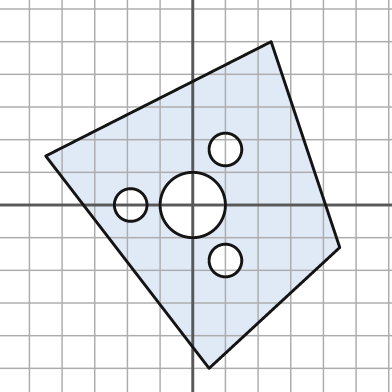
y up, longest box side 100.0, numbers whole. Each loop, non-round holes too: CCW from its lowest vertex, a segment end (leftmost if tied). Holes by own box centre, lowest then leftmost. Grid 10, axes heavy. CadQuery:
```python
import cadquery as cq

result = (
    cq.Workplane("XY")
    .moveTo(5.0, -50.0)
    .lineTo(45.0, -13.0)
    .lineTo(24.0, 50.0)
    .lineTo(-45.0, 15.0)
    .close()
    .moveTo(10.0, -17.0)
    .circle(5.0)
    .moveTo(-19.0, 0.0)
    .circle(5.0)
    .moveTo(0.0, 0.0)
    .circle(10.0)
    .moveTo(10.0, 17.0)
    .circle(5.0)
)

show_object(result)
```